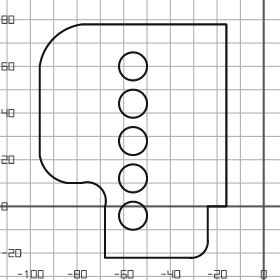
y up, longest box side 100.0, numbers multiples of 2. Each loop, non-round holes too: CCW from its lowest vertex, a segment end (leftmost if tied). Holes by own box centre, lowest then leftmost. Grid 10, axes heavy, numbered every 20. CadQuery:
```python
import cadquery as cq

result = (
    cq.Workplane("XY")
    .moveTo(-68.0, -22.0)
    .lineTo(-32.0, -22.0)
    .threePointArc((-26.0, -20.0), (-24.0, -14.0))
    .lineTo(-24.0, 0.0)
    .lineTo(-16.0, 0.0)
    .lineTo(-16.0, 78.0)
    .lineTo(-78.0, 78.0)
    .threePointArc((-90.0, 72.0), (-96.0, 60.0))
    .lineTo(-96.0, 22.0)
    .threePointArc((-92.0, 14.0), (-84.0, 10.0))
    .lineTo(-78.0, 10.0)
    .threePointArc((-70.0, 8.0), (-68.0, 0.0))
    .close()
    .moveTo(-56.0, -4.0)
    .circle(6.0)
    .moveTo(-56.0, 12.0)
    .circle(6.0)
    .moveTo(-56.0, 28.0)
    .circle(6.0)
    .moveTo(-56.0, 44.0)
    .circle(6.0)
    .moveTo(-56.0, 60.0)
    .circle(6.0)
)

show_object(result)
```